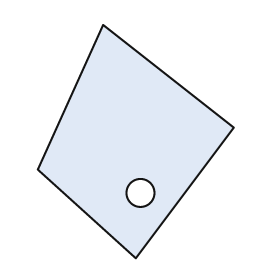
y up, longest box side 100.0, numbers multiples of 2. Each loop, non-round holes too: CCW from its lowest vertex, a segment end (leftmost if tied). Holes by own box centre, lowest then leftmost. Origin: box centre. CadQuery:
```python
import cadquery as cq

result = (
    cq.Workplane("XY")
    .moveTo(0.0, -50.0)
    .lineTo(42.0, 6.0)
    .lineTo(-14.0, 50.0)
    .lineTo(-42.0, -12.0)
    .close()
    .moveTo(2.0, -22.0)
    .circle(6.0)
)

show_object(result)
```